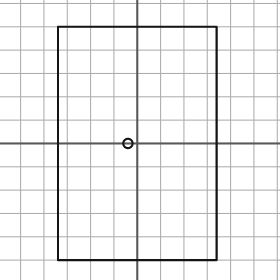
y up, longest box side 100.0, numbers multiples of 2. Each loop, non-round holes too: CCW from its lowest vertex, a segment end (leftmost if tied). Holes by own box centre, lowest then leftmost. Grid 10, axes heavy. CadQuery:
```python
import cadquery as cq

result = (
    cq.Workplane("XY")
    .moveTo(-34.0, -50.0)
    .lineTo(34.0, -50.0)
    .lineTo(34.0, 50.0)
    .lineTo(-34.0, 50.0)
    .close()
    .moveTo(-4.0, 0.0)
    .circle(2.0)
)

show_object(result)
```